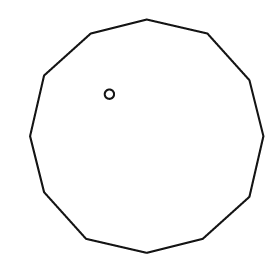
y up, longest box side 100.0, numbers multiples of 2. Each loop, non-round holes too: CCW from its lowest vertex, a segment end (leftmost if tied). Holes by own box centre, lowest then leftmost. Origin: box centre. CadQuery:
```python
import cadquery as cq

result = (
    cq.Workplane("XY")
    .moveTo(0.0, -50.0)
    .lineTo(24.0, -44.0)
    .lineTo(44.0, -26.0)
    .lineTo(50.0, 0.0)
    .lineTo(44.0, 24.0)
    .lineTo(26.0, 44.0)
    .lineTo(0.0, 50.0)
    .lineTo(-24.0, 44.0)
    .lineTo(-44.0, 26.0)
    .lineTo(-50.0, 0.0)
    .lineTo(-44.0, -24.0)
    .lineTo(-26.0, -44.0)
    .close()
    .moveTo(-16.0, 18.0)
    .circle(2.0)
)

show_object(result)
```